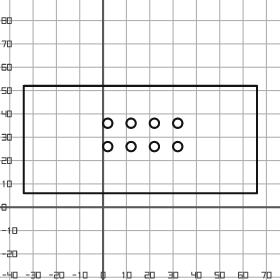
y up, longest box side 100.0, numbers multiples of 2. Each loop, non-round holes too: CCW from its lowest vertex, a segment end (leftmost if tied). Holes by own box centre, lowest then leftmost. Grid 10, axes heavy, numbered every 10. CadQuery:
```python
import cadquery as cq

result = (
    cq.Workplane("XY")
    .moveTo(-34.0, 6.0)
    .lineTo(66.0, 6.0)
    .lineTo(66.0, 52.0)
    .lineTo(-34.0, 52.0)
    .close()
    .moveTo(2.0, 26.0)
    .circle(2.0)
    .moveTo(12.0, 26.0)
    .circle(2.0)
    .moveTo(22.0, 26.0)
    .circle(2.0)
    .moveTo(32.0, 26.0)
    .circle(2.0)
    .moveTo(2.0, 36.0)
    .circle(2.0)
    .moveTo(12.0, 36.0)
    .circle(2.0)
    .moveTo(22.0, 36.0)
    .circle(2.0)
    .moveTo(32.0, 36.0)
    .circle(2.0)
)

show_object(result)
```